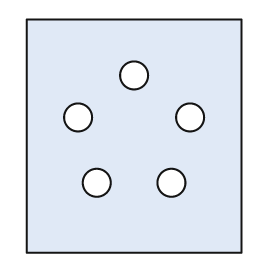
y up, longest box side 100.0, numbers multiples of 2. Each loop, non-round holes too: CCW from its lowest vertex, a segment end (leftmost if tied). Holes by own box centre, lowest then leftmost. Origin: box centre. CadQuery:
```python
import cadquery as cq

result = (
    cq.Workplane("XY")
    .moveTo(-46.0, -50.0)
    .lineTo(46.0, -50.0)
    .lineTo(46.0, 50.0)
    .lineTo(-46.0, 50.0)
    .close()
    .moveTo(-16.0, -20.0)
    .circle(6.0)
    .moveTo(16.0, -20.0)
    .circle(6.0)
    .moveTo(-24.0, 8.0)
    .circle(6.0)
    .moveTo(24.0, 8.0)
    .circle(6.0)
    .moveTo(0.0, 26.0)
    .circle(6.0)
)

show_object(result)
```